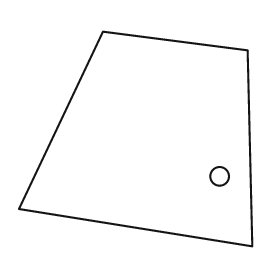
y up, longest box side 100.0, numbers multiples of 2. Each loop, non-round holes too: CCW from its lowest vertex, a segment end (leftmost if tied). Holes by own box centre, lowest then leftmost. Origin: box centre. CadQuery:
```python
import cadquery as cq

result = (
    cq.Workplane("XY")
    .moveTo(50.0, -46.0)
    .lineTo(48.0, 38.0)
    .lineTo(-14.0, 46.0)
    .lineTo(-50.0, -30.0)
    .close()
    .moveTo(36.0, -16.0)
    .circle(4.0)
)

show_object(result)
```